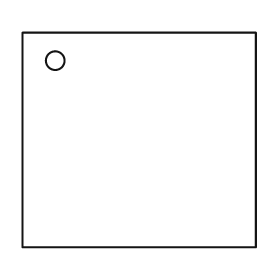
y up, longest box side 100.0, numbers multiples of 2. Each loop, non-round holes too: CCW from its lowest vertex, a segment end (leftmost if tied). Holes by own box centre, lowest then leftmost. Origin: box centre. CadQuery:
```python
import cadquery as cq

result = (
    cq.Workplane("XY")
    .moveTo(-50.0, -46.0)
    .lineTo(50.0, -46.0)
    .lineTo(50.0, 46.0)
    .lineTo(-50.0, 46.0)
    .close()
    .moveTo(-36.0, 34.0)
    .circle(4.0)
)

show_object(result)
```